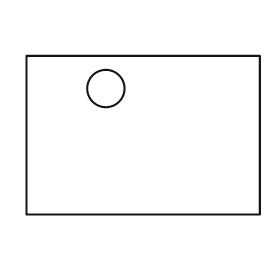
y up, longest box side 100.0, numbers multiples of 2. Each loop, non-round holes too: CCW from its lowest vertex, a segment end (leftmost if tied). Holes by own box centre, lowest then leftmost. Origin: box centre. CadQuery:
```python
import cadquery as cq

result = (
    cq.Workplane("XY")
    .moveTo(-50.0, -34.0)
    .lineTo(50.0, -34.0)
    .lineTo(50.0, 34.0)
    .lineTo(-50.0, 34.0)
    .close()
    .moveTo(-16.0, 20.0)
    .circle(8.0)
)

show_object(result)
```